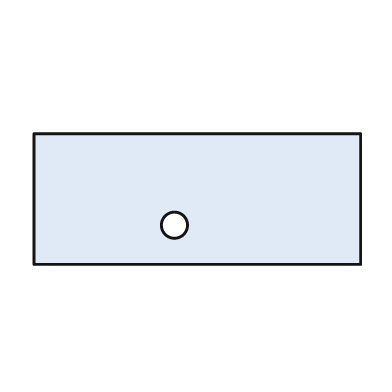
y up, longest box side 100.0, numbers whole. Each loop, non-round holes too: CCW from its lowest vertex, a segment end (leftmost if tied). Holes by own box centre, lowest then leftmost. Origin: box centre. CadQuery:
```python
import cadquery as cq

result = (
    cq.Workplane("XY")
    .moveTo(-50.0, -20.0)
    .lineTo(50.0, -20.0)
    .lineTo(50.0, 20.0)
    .lineTo(-50.0, 20.0)
    .close()
    .moveTo(-7.0, -8.0)
    .circle(4.0)
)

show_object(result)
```